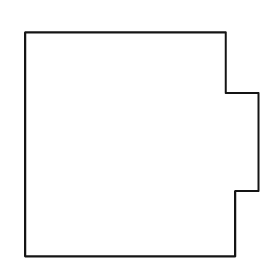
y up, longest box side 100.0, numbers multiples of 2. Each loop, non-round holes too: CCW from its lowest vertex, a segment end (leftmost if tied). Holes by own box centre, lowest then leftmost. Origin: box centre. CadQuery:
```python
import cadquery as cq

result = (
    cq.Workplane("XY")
    .moveTo(-50.0, -48.0)
    .lineTo(40.0, -48.0)
    .lineTo(40.0, -20.0)
    .lineTo(50.0, -20.0)
    .lineTo(50.0, 22.0)
    .lineTo(36.0, 22.0)
    .lineTo(36.0, 48.0)
    .lineTo(-50.0, 48.0)
    .close()
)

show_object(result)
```